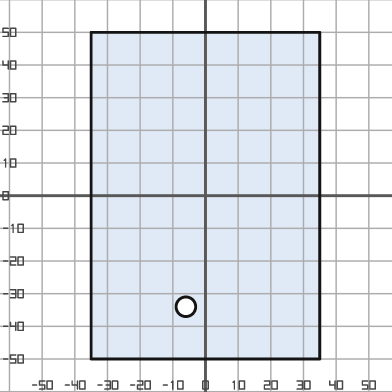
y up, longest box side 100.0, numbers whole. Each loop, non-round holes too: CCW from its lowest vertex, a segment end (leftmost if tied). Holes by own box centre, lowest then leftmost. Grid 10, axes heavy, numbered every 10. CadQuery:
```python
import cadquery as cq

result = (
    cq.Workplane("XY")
    .moveTo(-35.0, -50.0)
    .lineTo(35.0, -50.0)
    .lineTo(35.0, 50.0)
    .lineTo(-35.0, 50.0)
    .close()
    .moveTo(-6.0, -34.0)
    .circle(3.0)
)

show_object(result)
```